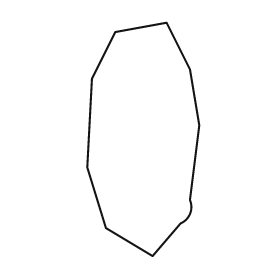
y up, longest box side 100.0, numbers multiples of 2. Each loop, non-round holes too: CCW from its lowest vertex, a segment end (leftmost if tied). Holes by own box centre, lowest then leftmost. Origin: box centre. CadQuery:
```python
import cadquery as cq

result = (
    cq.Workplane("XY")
    .moveTo(4.0, -50.0)
    .lineTo(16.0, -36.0)
    .threePointArc((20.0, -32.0), (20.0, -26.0))
    .lineTo(24.0, 6.0)
    .lineTo(20.0, 30.0)
    .lineTo(10.0, 50.0)
    .lineTo(-12.0, 46.0)
    .lineTo(-22.0, 26.0)
    .lineTo(-24.0, -12.0)
    .lineTo(-16.0, -38.0)
    .close()
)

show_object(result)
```